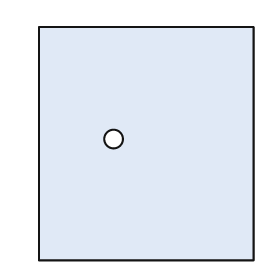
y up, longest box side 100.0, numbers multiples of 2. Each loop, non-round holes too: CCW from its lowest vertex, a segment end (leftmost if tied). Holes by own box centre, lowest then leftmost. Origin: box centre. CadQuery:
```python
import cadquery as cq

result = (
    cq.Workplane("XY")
    .moveTo(-46.0, -50.0)
    .lineTo(46.0, -50.0)
    .lineTo(46.0, 50.0)
    .lineTo(-46.0, 50.0)
    .close()
    .moveTo(-14.0, 2.0)
    .circle(4.0)
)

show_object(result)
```